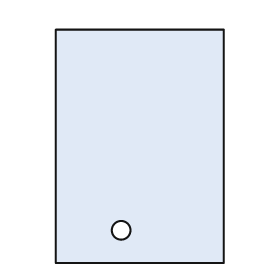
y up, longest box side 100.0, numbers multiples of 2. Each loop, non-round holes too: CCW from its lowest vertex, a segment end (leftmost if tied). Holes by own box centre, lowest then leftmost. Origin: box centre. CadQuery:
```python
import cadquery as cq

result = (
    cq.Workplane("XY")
    .moveTo(-36.0, -50.0)
    .lineTo(36.0, -50.0)
    .lineTo(36.0, 50.0)
    .lineTo(-36.0, 50.0)
    .close()
    .moveTo(-8.0, -36.0)
    .circle(4.0)
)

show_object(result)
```